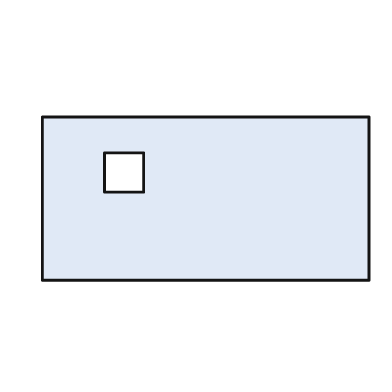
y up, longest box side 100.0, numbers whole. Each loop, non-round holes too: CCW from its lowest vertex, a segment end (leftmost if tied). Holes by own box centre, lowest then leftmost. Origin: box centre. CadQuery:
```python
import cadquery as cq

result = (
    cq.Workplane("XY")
    .moveTo(-50.0, -25.0)
    .lineTo(50.0, -25.0)
    .lineTo(50.0, 25.0)
    .lineTo(-50.0, 25.0)
    .close()
    .moveTo(-31.0, 2.0)
    .lineTo(-19.0, 2.0)
    .lineTo(-19.0, 14.0)
    .lineTo(-31.0, 14.0)
    .close()
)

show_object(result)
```